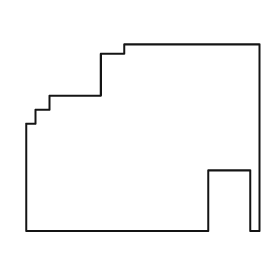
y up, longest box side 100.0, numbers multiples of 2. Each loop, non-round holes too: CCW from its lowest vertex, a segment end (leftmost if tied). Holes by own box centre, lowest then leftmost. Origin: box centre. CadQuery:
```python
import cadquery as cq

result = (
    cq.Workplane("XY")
    .moveTo(-50.0, -40.0)
    .lineTo(28.0, -40.0)
    .lineTo(28.0, -14.0)
    .lineTo(46.0, -14.0)
    .lineTo(46.0, -40.0)
    .lineTo(50.0, -40.0)
    .lineTo(50.0, 40.0)
    .lineTo(-8.0, 40.0)
    .lineTo(-8.0, 36.0)
    .lineTo(-18.0, 36.0)
    .lineTo(-18.0, 18.0)
    .lineTo(-40.0, 18.0)
    .lineTo(-40.0, 12.0)
    .lineTo(-46.0, 12.0)
    .lineTo(-46.0, 6.0)
    .lineTo(-50.0, 6.0)
    .close()
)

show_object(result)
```